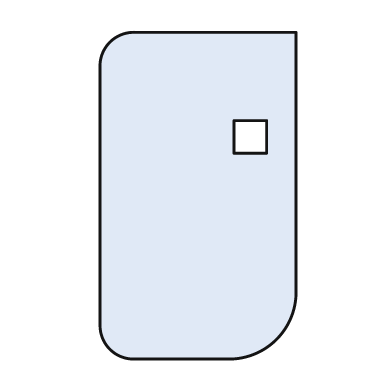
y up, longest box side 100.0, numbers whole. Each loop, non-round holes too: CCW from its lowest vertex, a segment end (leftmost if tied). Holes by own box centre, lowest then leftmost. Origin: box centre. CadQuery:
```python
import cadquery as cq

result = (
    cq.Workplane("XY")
    .moveTo(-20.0, -50.0)
    .lineTo(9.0, -50.0)
    .threePointArc((24.0, -44.0), (30.0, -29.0))
    .lineTo(30.0, 50.0)
    .lineTo(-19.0, 50.0)
    .threePointArc((-27.0, 47.0), (-30.0, 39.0))
    .lineTo(-30.0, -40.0)
    .threePointArc((-27.0, -47.0), (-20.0, -50.0))
    .close()
    .moveTo(11.0, 13.0)
    .lineTo(21.0, 13.0)
    .lineTo(21.0, 23.0)
    .lineTo(11.0, 23.0)
    .close()
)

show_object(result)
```